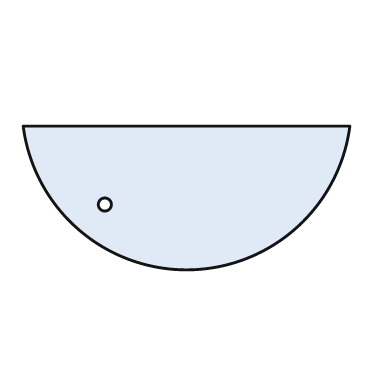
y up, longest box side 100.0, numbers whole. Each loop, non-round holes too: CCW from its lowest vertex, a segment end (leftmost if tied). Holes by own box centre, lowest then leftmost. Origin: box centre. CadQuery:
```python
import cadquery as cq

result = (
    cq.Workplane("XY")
    .moveTo(-50.0, 22.0)
    .threePointArc((0.0, -22.0), (50.0, 22.0))
    .close()
    .moveTo(-25.0, -2.0)
    .circle(2.0)
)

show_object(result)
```